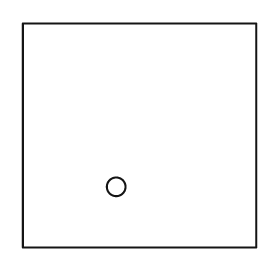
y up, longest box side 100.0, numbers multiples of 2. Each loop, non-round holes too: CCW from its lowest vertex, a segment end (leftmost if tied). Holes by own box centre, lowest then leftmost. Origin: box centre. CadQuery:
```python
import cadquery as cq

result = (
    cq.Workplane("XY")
    .moveTo(-50.0, -48.0)
    .lineTo(50.0, -48.0)
    .lineTo(50.0, 48.0)
    .lineTo(-50.0, 48.0)
    .close()
    .moveTo(-10.0, -22.0)
    .circle(4.0)
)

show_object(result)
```